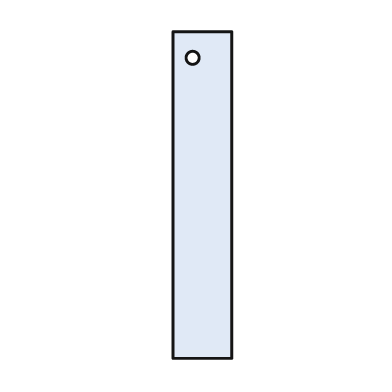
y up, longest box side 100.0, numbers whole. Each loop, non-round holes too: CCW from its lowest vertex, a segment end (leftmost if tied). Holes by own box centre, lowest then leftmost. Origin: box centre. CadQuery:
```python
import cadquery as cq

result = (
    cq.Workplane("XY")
    .moveTo(-9.0, -50.0)
    .lineTo(9.0, -50.0)
    .lineTo(9.0, 50.0)
    .lineTo(-9.0, 50.0)
    .close()
    .moveTo(-3.0, 42.0)
    .circle(2.0)
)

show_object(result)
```